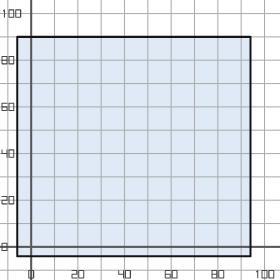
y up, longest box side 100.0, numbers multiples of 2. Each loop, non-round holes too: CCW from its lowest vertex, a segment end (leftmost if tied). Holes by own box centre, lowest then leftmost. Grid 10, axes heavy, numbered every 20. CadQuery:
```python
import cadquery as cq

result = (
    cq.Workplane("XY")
    .moveTo(-6.0, -4.0)
    .lineTo(94.0, -4.0)
    .lineTo(94.0, 90.0)
    .lineTo(-6.0, 90.0)
    .close()
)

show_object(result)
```